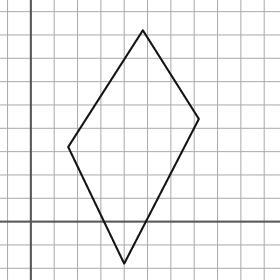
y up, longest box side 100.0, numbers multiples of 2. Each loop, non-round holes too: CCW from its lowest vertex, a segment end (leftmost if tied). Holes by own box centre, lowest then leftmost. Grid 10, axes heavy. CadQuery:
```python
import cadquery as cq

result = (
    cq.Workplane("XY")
    .moveTo(40.0, -18.0)
    .lineTo(72.0, 44.0)
    .lineTo(48.0, 82.0)
    .lineTo(16.0, 32.0)
    .close()
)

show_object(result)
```